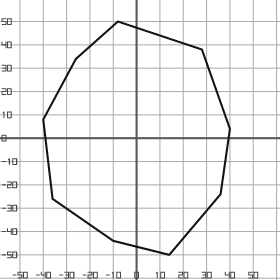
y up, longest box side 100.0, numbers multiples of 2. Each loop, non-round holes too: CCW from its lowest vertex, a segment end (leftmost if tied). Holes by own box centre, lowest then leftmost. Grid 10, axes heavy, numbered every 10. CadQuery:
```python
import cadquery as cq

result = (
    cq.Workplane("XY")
    .moveTo(14.0, -50.0)
    .lineTo(36.0, -24.0)
    .lineTo(40.0, 4.0)
    .lineTo(28.0, 38.0)
    .lineTo(-8.0, 50.0)
    .lineTo(-26.0, 34.0)
    .lineTo(-40.0, 8.0)
    .lineTo(-36.0, -26.0)
    .lineTo(-10.0, -44.0)
    .close()
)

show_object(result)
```